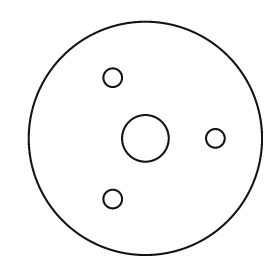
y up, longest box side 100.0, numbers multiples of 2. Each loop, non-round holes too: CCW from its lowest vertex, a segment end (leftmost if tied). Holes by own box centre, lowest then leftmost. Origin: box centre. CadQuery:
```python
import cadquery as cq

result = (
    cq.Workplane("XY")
    .moveTo(0.0, 0.0)
    .circle(50.0)
    .moveTo(-14.0, -26.0)
    .circle(4.0)
    .moveTo(0.0, 0.0)
    .circle(10.0)
    .moveTo(30.0, 0.0)
    .circle(4.0)
    .moveTo(-14.0, 26.0)
    .circle(4.0)
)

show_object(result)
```